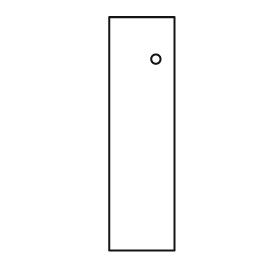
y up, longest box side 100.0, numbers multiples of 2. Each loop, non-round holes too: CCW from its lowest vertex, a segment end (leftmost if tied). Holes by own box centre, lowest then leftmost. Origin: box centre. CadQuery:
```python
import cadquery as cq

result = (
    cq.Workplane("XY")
    .moveTo(-14.0, -50.0)
    .lineTo(14.0, -50.0)
    .lineTo(14.0, 50.0)
    .lineTo(-14.0, 50.0)
    .close()
    .moveTo(6.0, 32.0)
    .circle(2.0)
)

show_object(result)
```